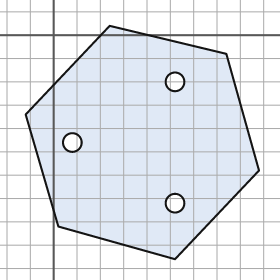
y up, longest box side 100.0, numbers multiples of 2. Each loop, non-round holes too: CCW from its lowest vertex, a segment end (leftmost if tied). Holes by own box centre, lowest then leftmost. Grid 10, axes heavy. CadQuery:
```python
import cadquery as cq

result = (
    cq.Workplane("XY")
    .moveTo(52.0, -96.0)
    .lineTo(88.0, -58.0)
    .lineTo(74.0, -8.0)
    .lineTo(24.0, 4.0)
    .lineTo(-12.0, -34.0)
    .lineTo(2.0, -82.0)
    .close()
    .moveTo(52.0, -72.0)
    .circle(4.0)
    .moveTo(8.0, -46.0)
    .circle(4.0)
    .moveTo(52.0, -20.0)
    .circle(4.0)
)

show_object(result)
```